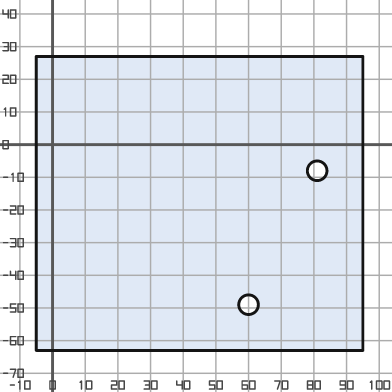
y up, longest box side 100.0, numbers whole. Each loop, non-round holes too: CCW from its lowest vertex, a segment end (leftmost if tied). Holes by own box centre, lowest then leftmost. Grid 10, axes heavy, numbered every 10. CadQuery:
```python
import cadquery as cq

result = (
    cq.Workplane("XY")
    .moveTo(-5.0, -63.0)
    .lineTo(95.0, -63.0)
    .lineTo(95.0, 27.0)
    .lineTo(-5.0, 27.0)
    .close()
    .moveTo(60.0, -49.0)
    .circle(3.0)
    .moveTo(81.0, -8.0)
    .circle(3.0)
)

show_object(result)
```